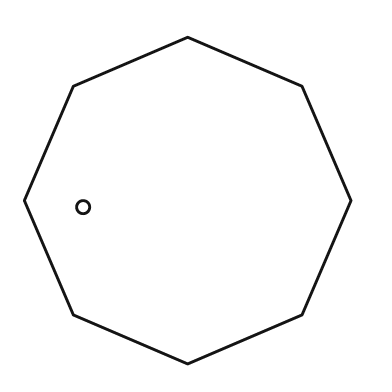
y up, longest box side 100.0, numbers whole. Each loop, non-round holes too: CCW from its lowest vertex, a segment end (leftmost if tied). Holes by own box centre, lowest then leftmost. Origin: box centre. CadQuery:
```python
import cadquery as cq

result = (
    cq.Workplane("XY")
    .moveTo(0.0, -50.0)
    .lineTo(35.0, -35.0)
    .lineTo(50.0, 0.0)
    .lineTo(35.0, 35.0)
    .lineTo(0.0, 50.0)
    .lineTo(-35.0, 35.0)
    .lineTo(-50.0, 0.0)
    .lineTo(-35.0, -35.0)
    .close()
    .moveTo(-32.0, -2.0)
    .circle(2.0)
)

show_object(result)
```